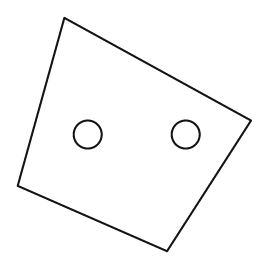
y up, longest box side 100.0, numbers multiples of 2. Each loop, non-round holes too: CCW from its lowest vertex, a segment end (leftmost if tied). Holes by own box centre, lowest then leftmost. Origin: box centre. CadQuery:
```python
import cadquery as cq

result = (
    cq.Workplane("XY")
    .moveTo(14.0, -50.0)
    .lineTo(50.0, 6.0)
    .lineTo(-30.0, 50.0)
    .lineTo(-50.0, -22.0)
    .close()
    .moveTo(-20.0, 0.0)
    .circle(6.0)
    .moveTo(22.0, 0.0)
    .circle(6.0)
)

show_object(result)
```